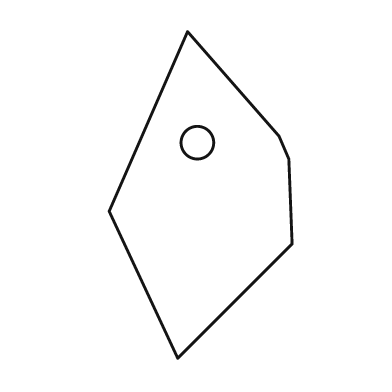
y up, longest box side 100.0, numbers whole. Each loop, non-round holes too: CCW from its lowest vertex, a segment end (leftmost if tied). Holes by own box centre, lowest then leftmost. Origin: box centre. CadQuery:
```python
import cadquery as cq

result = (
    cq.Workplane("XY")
    .moveTo(-7.0, -50.0)
    .lineTo(28.0, -15.0)
    .lineTo(27.0, 11.0)
    .lineTo(24.0, 18.0)
    .lineTo(-4.0, 50.0)
    .lineTo(-28.0, -5.0)
    .close()
    .moveTo(-1.0, 16.0)
    .circle(5.0)
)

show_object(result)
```